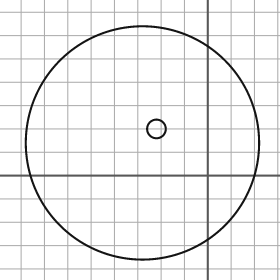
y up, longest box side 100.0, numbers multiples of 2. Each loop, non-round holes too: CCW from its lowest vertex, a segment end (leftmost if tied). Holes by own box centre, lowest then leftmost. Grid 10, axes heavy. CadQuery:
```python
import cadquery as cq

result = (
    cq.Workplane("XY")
    .moveTo(-28.0, 14.0)
    .circle(50.0)
    .moveTo(-22.0, 20.0)
    .circle(4.0)
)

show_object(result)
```